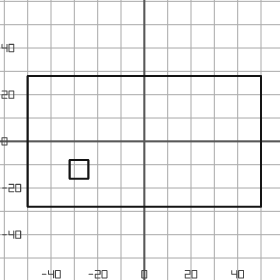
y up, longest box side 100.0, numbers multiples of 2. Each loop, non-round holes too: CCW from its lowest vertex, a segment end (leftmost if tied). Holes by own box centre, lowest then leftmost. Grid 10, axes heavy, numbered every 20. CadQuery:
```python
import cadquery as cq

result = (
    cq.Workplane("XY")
    .moveTo(-50.0, -28.0)
    .lineTo(50.0, -28.0)
    .lineTo(50.0, 28.0)
    .lineTo(-50.0, 28.0)
    .close()
    .moveTo(-32.0, -16.0)
    .lineTo(-24.0, -16.0)
    .lineTo(-24.0, -8.0)
    .lineTo(-32.0, -8.0)
    .close()
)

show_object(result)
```